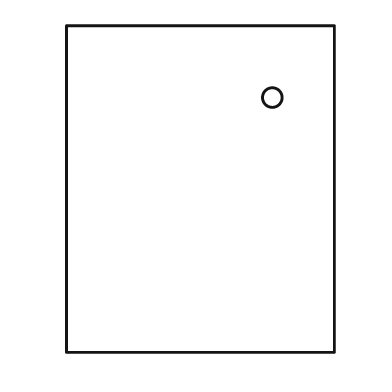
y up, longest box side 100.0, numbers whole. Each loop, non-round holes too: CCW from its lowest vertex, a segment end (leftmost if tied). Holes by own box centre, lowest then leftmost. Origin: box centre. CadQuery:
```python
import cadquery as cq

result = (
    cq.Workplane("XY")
    .moveTo(-41.0, -50.0)
    .lineTo(41.0, -50.0)
    .lineTo(41.0, 50.0)
    .lineTo(-41.0, 50.0)
    .close()
    .moveTo(22.0, 28.0)
    .circle(3.0)
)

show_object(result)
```